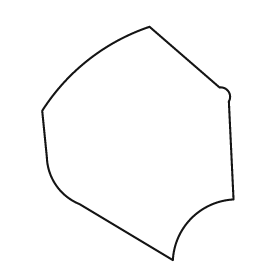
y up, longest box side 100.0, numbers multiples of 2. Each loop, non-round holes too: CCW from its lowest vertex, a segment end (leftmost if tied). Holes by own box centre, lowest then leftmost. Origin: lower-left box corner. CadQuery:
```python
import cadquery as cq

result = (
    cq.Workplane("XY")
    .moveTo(56.0, 0.0)
    .threePointArc((64.0, 18.0), (82.0, 26.0))
    .lineTo(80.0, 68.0)
    .threePointArc((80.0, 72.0), (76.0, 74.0))
    .lineTo(46.0, 100.0)
    .threePointArc((20.0, 86.0), (0.0, 64.0))
    .lineTo(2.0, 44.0)
    .threePointArc((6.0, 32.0), (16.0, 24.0))
    .close()
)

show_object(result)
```